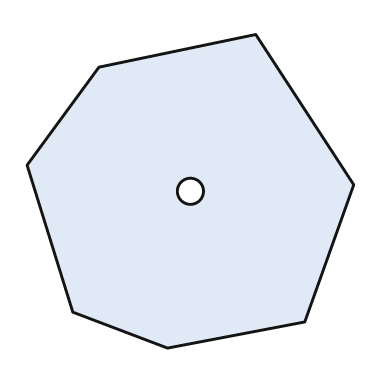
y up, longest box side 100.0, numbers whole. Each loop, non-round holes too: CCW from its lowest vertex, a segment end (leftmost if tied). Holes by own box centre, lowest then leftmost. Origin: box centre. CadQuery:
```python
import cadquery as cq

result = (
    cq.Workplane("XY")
    .moveTo(-7.0, -48.0)
    .lineTo(35.0, -40.0)
    .lineTo(50.0, 2.0)
    .lineTo(20.0, 48.0)
    .lineTo(-28.0, 38.0)
    .lineTo(-50.0, 8.0)
    .lineTo(-36.0, -37.0)
    .close()
    .moveTo(0.0, 0.0)
    .circle(4.0)
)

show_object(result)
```